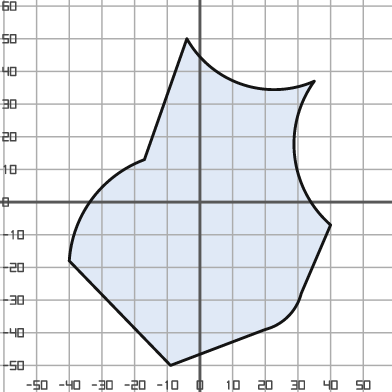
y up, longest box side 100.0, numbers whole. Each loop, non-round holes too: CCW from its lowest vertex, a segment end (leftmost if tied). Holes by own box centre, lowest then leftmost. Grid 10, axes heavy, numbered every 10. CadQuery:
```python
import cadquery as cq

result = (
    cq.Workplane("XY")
    .moveTo(-9.0, -50.0)
    .lineTo(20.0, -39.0)
    .threePointArc((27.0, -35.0), (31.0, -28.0))
    .lineTo(40.0, -7.0)
    .threePointArc((29.0, 14.0), (35.0, 37.0))
    .threePointArc((13.0, 36.0), (-4.0, 50.0))
    .lineTo(-17.0, 13.0)
    .threePointArc((-33.0, 1.0), (-40.0, -18.0))
    .close()
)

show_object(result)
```